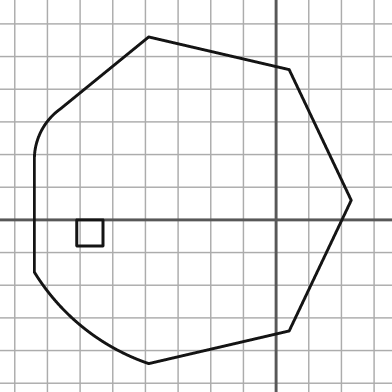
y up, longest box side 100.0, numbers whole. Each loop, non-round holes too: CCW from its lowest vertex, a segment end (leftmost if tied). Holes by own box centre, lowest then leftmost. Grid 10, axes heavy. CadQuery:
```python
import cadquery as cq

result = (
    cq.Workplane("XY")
    .moveTo(-39.0, -44.0)
    .lineTo(4.0, -34.0)
    .lineTo(23.0, 6.0)
    .lineTo(4.0, 46.0)
    .lineTo(-39.0, 56.0)
    .lineTo(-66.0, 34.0)
    .threePointArc((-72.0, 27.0), (-74.0, 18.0))
    .lineTo(-74.0, -16.0)
    .threePointArc((-59.0, -33.0), (-39.0, -44.0))
    .close()
    .moveTo(-61.0, -8.0)
    .lineTo(-53.0, -8.0)
    .lineTo(-53.0, 0.0)
    .lineTo(-61.0, 0.0)
    .close()
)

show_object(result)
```